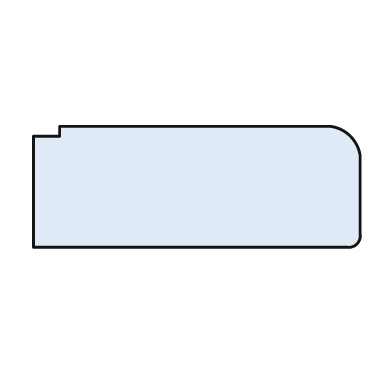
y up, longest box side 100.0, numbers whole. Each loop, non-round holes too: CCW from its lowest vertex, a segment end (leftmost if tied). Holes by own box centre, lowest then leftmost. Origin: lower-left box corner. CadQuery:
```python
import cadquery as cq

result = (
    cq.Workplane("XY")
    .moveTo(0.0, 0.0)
    .lineTo(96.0, 0.0)
    .threePointArc((99.0, 1.0), (100.0, 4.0))
    .lineTo(100.0, 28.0)
    .threePointArc((97.0, 34.0), (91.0, 37.0))
    .lineTo(8.0, 37.0)
    .lineTo(8.0, 34.0)
    .lineTo(0.0, 34.0)
    .close()
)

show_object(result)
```